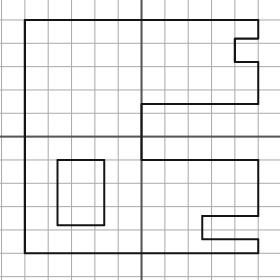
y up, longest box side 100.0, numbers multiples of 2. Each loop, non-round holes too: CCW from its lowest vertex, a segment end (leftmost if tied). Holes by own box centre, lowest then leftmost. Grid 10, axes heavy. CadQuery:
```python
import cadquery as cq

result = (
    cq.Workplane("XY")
    .moveTo(-50.0, -50.0)
    .lineTo(50.0, -50.0)
    .lineTo(50.0, -44.0)
    .lineTo(26.0, -44.0)
    .lineTo(26.0, -34.0)
    .lineTo(50.0, -34.0)
    .lineTo(50.0, -10.0)
    .lineTo(0.0, -10.0)
    .lineTo(0.0, 14.0)
    .lineTo(50.0, 14.0)
    .lineTo(50.0, 32.0)
    .lineTo(40.0, 32.0)
    .lineTo(40.0, 42.0)
    .lineTo(50.0, 42.0)
    .lineTo(50.0, 50.0)
    .lineTo(-50.0, 50.0)
    .close()
    .moveTo(-36.0, -38.0)
    .lineTo(-16.0, -38.0)
    .lineTo(-16.0, -10.0)
    .lineTo(-36.0, -10.0)
    .close()
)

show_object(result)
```